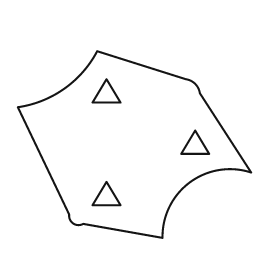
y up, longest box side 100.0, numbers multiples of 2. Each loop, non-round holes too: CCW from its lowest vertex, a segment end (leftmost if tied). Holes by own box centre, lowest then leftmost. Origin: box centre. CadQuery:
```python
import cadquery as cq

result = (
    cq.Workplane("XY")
    .moveTo(12.0, -40.0)
    .threePointArc((24.0, -16.0), (50.0, -12.0))
    .lineTo(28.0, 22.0)
    .threePointArc((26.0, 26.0), (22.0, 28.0))
    .lineTo(-16.0, 40.0)
    .threePointArc((-30.0, 24.0), (-50.0, 16.0))
    .lineTo(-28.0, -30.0)
    .threePointArc((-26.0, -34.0), (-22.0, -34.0))
    .close()
    .moveTo(-18.0, -26.0)
    .lineTo(-6.0, -26.0)
    .lineTo(-12.0, -16.0)
    .close()
    .moveTo(20.0, -4.0)
    .lineTo(32.0, -4.0)
    .lineTo(26.0, 6.0)
    .close()
    .moveTo(-18.0, 18.0)
    .lineTo(-6.0, 18.0)
    .lineTo(-12.0, 28.0)
    .close()
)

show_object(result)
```